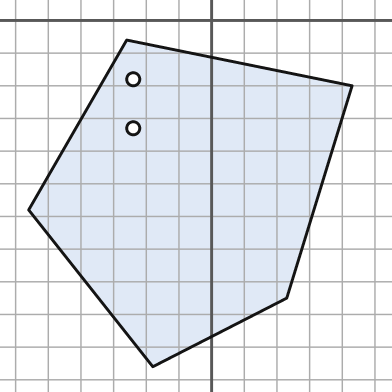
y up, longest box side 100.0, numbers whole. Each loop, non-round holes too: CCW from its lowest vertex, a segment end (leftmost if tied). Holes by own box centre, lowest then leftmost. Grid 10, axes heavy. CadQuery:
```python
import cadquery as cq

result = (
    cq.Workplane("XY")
    .moveTo(-18.0, -106.0)
    .lineTo(23.0, -85.0)
    .lineTo(43.0, -20.0)
    .lineTo(-26.0, -6.0)
    .lineTo(-56.0, -58.0)
    .close()
    .moveTo(-24.0, -33.0)
    .circle(2.0)
    .moveTo(-24.0, -18.0)
    .circle(2.0)
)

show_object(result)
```